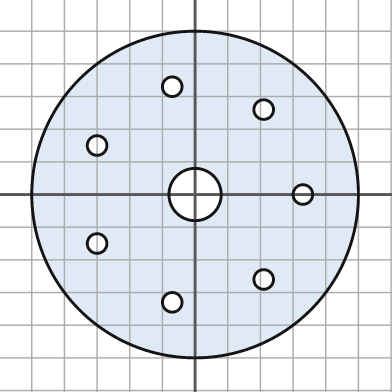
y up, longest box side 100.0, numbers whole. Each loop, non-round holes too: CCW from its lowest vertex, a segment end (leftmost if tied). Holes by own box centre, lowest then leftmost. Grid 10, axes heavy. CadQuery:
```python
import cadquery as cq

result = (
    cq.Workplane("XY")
    .moveTo(0.0, 0.0)
    .circle(50.0)
    .moveTo(-7.0, -33.0)
    .circle(3.0)
    .moveTo(21.0, -26.0)
    .circle(3.0)
    .moveTo(-30.0, -15.0)
    .circle(3.0)
    .moveTo(0.0, 0.0)
    .circle(8.0)
    .moveTo(33.0, 0.0)
    .circle(3.0)
    .moveTo(-30.0, 15.0)
    .circle(3.0)
    .moveTo(21.0, 26.0)
    .circle(3.0)
    .moveTo(-7.0, 33.0)
    .circle(3.0)
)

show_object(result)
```